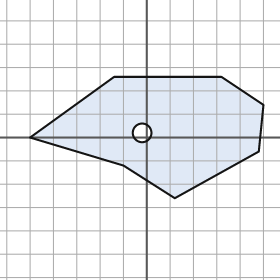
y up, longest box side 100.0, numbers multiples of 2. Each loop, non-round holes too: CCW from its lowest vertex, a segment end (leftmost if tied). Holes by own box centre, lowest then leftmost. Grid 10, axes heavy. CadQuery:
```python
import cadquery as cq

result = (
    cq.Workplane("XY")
    .moveTo(12.0, -26.0)
    .lineTo(48.0, -6.0)
    .lineTo(50.0, 14.0)
    .lineTo(32.0, 26.0)
    .lineTo(-14.0, 26.0)
    .lineTo(-50.0, 0.0)
    .lineTo(-10.0, -12.0)
    .close()
    .moveTo(-2.0, 2.0)
    .circle(4.0)
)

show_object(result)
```